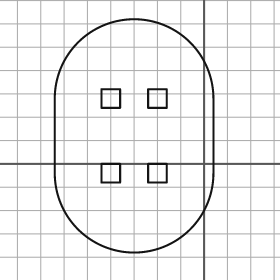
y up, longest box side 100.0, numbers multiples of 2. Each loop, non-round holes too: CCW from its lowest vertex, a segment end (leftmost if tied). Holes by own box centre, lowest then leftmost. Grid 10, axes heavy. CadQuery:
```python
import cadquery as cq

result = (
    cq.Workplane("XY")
    .moveTo(-64.0, -4.0)
    .threePointArc((-30.0, -38.0), (4.0, -4.0))
    .lineTo(4.0, 28.0)
    .threePointArc((-30.0, 62.0), (-64.0, 28.0))
    .close()
    .moveTo(-44.0, -8.0)
    .lineTo(-36.0, -8.0)
    .lineTo(-36.0, 0.0)
    .lineTo(-44.0, 0.0)
    .close()
    .moveTo(-24.0, -8.0)
    .lineTo(-16.0, -8.0)
    .lineTo(-16.0, 0.0)
    .lineTo(-24.0, 0.0)
    .close()
    .moveTo(-44.0, 24.0)
    .lineTo(-36.0, 24.0)
    .lineTo(-36.0, 32.0)
    .lineTo(-44.0, 32.0)
    .close()
    .moveTo(-24.0, 24.0)
    .lineTo(-16.0, 24.0)
    .lineTo(-16.0, 32.0)
    .lineTo(-24.0, 32.0)
    .close()
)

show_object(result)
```